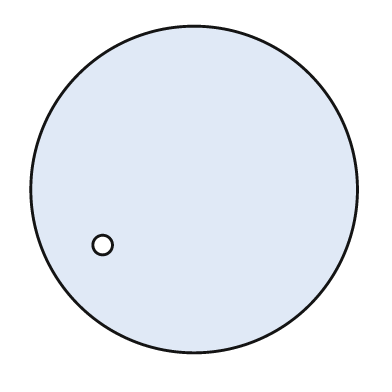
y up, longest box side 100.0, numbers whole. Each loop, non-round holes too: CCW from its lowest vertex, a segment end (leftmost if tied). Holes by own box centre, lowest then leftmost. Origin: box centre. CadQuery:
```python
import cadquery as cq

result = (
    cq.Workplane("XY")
    .moveTo(0.0, 0.0)
    .circle(50.0)
    .moveTo(-28.0, -17.0)
    .circle(3.0)
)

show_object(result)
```